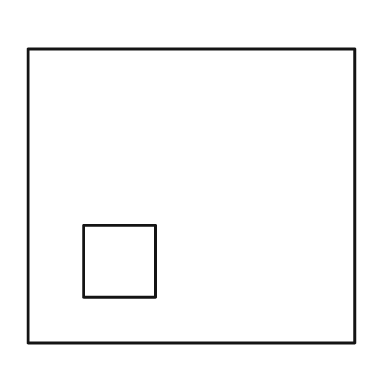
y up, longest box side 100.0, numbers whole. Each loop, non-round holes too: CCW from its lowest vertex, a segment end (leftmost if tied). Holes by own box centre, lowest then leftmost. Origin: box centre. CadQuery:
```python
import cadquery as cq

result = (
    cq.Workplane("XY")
    .moveTo(-50.0, -45.0)
    .lineTo(50.0, -45.0)
    .lineTo(50.0, 45.0)
    .lineTo(-50.0, 45.0)
    .close()
    .moveTo(-33.0, -31.0)
    .lineTo(-11.0, -31.0)
    .lineTo(-11.0, -9.0)
    .lineTo(-33.0, -9.0)
    .close()
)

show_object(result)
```